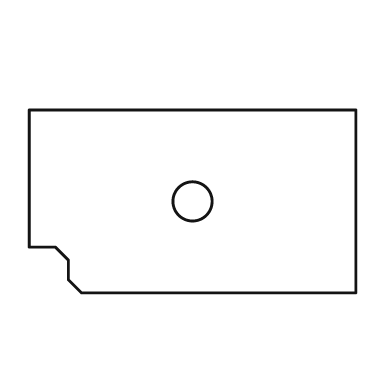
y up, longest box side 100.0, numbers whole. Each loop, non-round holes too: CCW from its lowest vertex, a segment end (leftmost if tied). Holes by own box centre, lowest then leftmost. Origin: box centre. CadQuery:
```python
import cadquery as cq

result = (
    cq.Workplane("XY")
    .moveTo(-34.0, -28.0)
    .lineTo(50.0, -28.0)
    .lineTo(50.0, 28.0)
    .lineTo(-50.0, 28.0)
    .lineTo(-50.0, -14.0)
    .lineTo(-42.0, -14.0)
    .lineTo(-38.0, -18.0)
    .lineTo(-38.0, -24.0)
    .close()
    .moveTo(0.0, 0.0)
    .circle(6.0)
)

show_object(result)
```